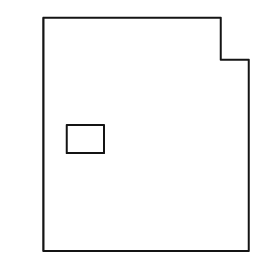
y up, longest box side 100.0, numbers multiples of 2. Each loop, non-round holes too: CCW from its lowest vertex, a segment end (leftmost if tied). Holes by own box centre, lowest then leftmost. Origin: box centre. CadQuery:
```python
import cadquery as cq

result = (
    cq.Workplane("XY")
    .moveTo(-44.0, -50.0)
    .lineTo(44.0, -50.0)
    .lineTo(44.0, 32.0)
    .lineTo(32.0, 32.0)
    .lineTo(32.0, 50.0)
    .lineTo(-44.0, 50.0)
    .close()
    .moveTo(-34.0, -8.0)
    .lineTo(-18.0, -8.0)
    .lineTo(-18.0, 4.0)
    .lineTo(-34.0, 4.0)
    .close()
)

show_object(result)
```